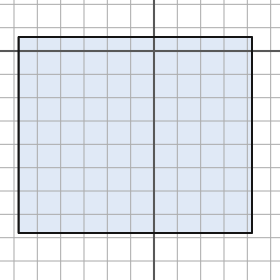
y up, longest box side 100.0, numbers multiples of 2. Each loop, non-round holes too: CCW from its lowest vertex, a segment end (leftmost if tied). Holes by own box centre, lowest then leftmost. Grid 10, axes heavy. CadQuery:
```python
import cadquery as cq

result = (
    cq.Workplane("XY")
    .moveTo(-58.0, -78.0)
    .lineTo(42.0, -78.0)
    .lineTo(42.0, 6.0)
    .lineTo(-58.0, 6.0)
    .close()
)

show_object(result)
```